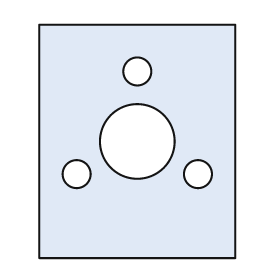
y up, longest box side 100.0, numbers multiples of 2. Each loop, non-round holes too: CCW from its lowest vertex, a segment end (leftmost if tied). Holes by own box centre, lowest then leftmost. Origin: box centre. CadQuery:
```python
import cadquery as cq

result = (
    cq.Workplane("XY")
    .moveTo(-42.0, -50.0)
    .lineTo(42.0, -50.0)
    .lineTo(42.0, 50.0)
    .lineTo(-42.0, 50.0)
    .close()
    .moveTo(-26.0, -14.0)
    .circle(6.0)
    .moveTo(26.0, -14.0)
    .circle(6.0)
    .moveTo(0.0, 0.0)
    .circle(16.0)
    .moveTo(0.0, 30.0)
    .circle(6.0)
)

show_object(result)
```